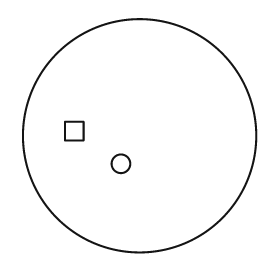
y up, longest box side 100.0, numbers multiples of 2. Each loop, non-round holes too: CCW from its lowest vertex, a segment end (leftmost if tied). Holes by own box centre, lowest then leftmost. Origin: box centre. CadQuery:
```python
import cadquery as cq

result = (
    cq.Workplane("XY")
    .moveTo(0.0, 0.0)
    .circle(50.0)
    .moveTo(-8.0, -12.0)
    .circle(4.0)
    .moveTo(-32.0, -2.0)
    .lineTo(-24.0, -2.0)
    .lineTo(-24.0, 6.0)
    .lineTo(-32.0, 6.0)
    .close()
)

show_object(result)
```